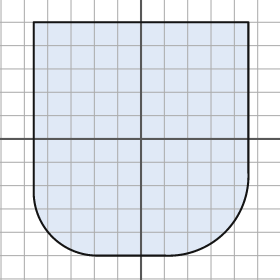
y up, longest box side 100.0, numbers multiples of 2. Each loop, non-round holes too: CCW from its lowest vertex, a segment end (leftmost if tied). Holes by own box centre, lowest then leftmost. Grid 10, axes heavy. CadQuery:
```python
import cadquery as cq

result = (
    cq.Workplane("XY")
    .moveTo(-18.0, -50.0)
    .lineTo(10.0, -50.0)
    .threePointArc((36.0, -40.0), (46.0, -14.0))
    .lineTo(46.0, 50.0)
    .lineTo(-46.0, 50.0)
    .lineTo(-46.0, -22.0)
    .threePointArc((-38.0, -42.0), (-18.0, -50.0))
    .close()
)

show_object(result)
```